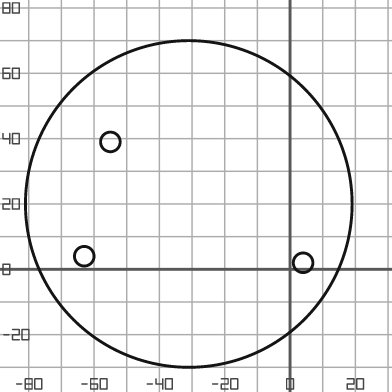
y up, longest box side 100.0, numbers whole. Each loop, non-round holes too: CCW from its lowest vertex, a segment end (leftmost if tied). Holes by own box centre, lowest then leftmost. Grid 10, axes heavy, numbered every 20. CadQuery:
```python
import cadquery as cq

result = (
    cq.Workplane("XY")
    .moveTo(-31.0, 20.0)
    .circle(50.0)
    .moveTo(4.0, 2.0)
    .circle(3.0)
    .moveTo(-63.0, 4.0)
    .circle(3.0)
    .moveTo(-55.0, 39.0)
    .circle(3.0)
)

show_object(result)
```